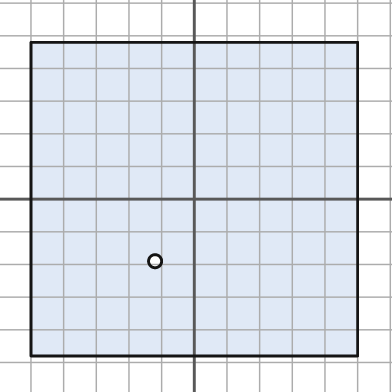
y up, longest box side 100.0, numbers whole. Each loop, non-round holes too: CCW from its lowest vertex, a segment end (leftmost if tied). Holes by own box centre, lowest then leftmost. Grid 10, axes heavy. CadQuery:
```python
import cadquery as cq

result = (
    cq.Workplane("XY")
    .moveTo(-50.0, -48.0)
    .lineTo(50.0, -48.0)
    .lineTo(50.0, 48.0)
    .lineTo(-50.0, 48.0)
    .close()
    .moveTo(-12.0, -19.0)
    .circle(2.0)
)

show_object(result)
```